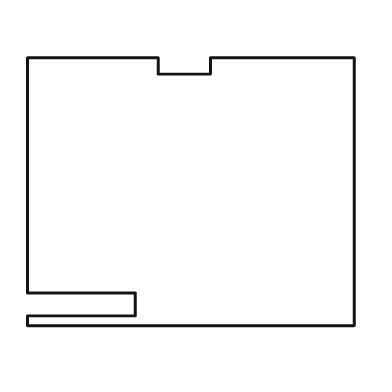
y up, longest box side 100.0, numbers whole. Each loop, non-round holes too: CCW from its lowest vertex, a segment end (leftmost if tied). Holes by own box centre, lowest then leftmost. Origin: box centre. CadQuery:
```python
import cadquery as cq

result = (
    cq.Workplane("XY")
    .moveTo(-50.0, -41.0)
    .lineTo(50.0, -41.0)
    .lineTo(50.0, 41.0)
    .lineTo(6.0, 41.0)
    .lineTo(6.0, 36.0)
    .lineTo(-10.0, 36.0)
    .lineTo(-10.0, 41.0)
    .lineTo(-50.0, 41.0)
    .lineTo(-50.0, -31.0)
    .lineTo(-17.0, -31.0)
    .lineTo(-17.0, -38.0)
    .lineTo(-50.0, -38.0)
    .close()
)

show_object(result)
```